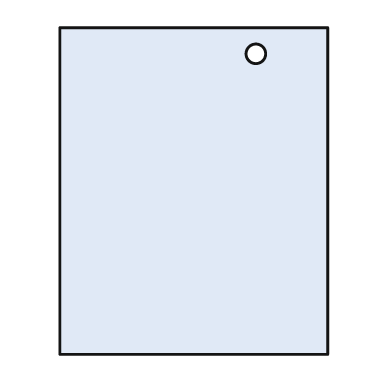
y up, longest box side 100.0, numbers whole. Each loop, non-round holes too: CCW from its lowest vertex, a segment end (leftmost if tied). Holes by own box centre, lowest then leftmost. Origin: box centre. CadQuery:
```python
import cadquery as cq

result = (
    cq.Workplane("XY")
    .moveTo(-41.0, -50.0)
    .lineTo(41.0, -50.0)
    .lineTo(41.0, 50.0)
    .lineTo(-41.0, 50.0)
    .close()
    .moveTo(19.0, 42.0)
    .circle(3.0)
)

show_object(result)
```